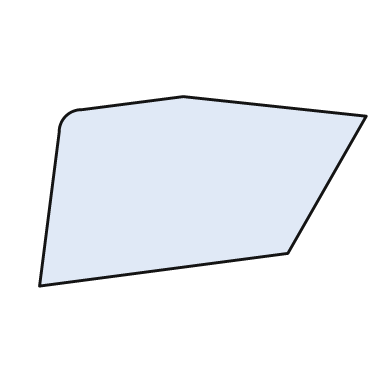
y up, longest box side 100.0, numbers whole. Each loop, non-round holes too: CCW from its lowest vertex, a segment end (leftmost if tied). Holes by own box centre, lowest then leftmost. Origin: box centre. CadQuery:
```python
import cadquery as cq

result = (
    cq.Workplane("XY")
    .moveTo(-50.0, -29.0)
    .lineTo(26.0, -19.0)
    .lineTo(50.0, 23.0)
    .lineTo(-6.0, 29.0)
    .lineTo(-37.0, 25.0)
    .threePointArc((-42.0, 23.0), (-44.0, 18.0))
    .close()
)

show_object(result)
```